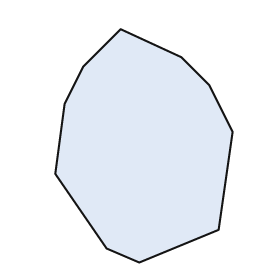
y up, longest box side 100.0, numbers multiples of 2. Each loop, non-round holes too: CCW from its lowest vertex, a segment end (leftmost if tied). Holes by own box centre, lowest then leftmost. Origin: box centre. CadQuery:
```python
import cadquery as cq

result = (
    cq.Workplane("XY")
    .moveTo(-2.0, -50.0)
    .lineTo(32.0, -36.0)
    .lineTo(38.0, 6.0)
    .lineTo(28.0, 26.0)
    .lineTo(16.0, 38.0)
    .lineTo(-10.0, 50.0)
    .lineTo(-26.0, 34.0)
    .lineTo(-34.0, 18.0)
    .lineTo(-38.0, -12.0)
    .lineTo(-16.0, -44.0)
    .close()
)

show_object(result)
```